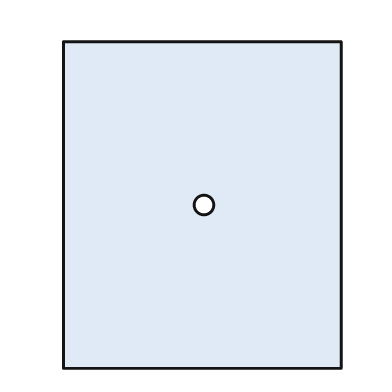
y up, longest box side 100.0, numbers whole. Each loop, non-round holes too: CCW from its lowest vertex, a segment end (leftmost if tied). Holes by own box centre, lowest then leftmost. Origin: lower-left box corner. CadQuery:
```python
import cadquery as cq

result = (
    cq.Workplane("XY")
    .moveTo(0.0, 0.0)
    .lineTo(85.0, 0.0)
    .lineTo(85.0, 100.0)
    .lineTo(0.0, 100.0)
    .close()
    .moveTo(43.0, 50.0)
    .circle(3.0)
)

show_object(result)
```